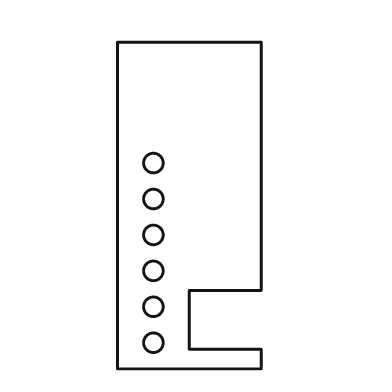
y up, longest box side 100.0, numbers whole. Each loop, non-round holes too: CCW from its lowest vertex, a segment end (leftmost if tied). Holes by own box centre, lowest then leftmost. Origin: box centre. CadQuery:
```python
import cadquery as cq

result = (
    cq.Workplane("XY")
    .moveTo(-22.0, -50.0)
    .lineTo(22.0, -50.0)
    .lineTo(22.0, -44.0)
    .lineTo(0.0, -44.0)
    .lineTo(0.0, -26.0)
    .lineTo(22.0, -26.0)
    .lineTo(22.0, 50.0)
    .lineTo(-22.0, 50.0)
    .close()
    .moveTo(-11.0, -42.0)
    .circle(3.0)
    .moveTo(-11.0, -31.0)
    .circle(3.0)
    .moveTo(-11.0, -20.0)
    .circle(3.0)
    .moveTo(-11.0, -9.0)
    .circle(3.0)
    .moveTo(-11.0, 2.0)
    .circle(3.0)
    .moveTo(-11.0, 13.0)
    .circle(3.0)
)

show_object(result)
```